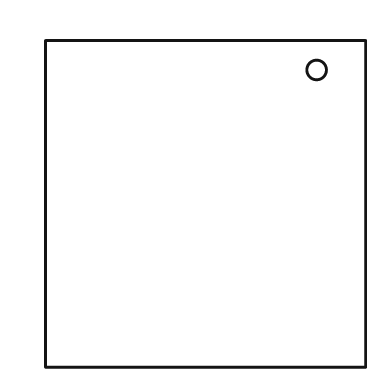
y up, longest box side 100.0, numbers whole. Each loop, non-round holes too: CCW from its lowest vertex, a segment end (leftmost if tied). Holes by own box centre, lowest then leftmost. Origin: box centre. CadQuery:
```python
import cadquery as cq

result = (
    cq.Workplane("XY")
    .moveTo(-49.0, -50.0)
    .lineTo(49.0, -50.0)
    .lineTo(49.0, 50.0)
    .lineTo(-49.0, 50.0)
    .close()
    .moveTo(34.0, 41.0)
    .circle(3.0)
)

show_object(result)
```